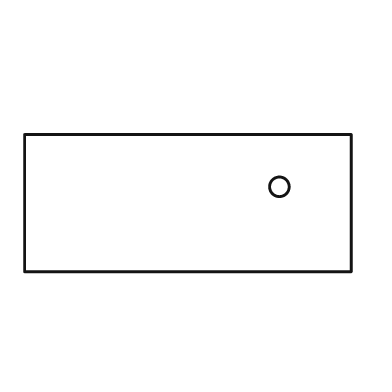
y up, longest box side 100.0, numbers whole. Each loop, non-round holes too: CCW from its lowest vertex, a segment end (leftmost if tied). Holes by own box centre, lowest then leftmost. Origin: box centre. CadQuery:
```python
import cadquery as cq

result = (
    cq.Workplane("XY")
    .moveTo(-50.0, -21.0)
    .lineTo(50.0, -21.0)
    .lineTo(50.0, 21.0)
    .lineTo(-50.0, 21.0)
    .close()
    .moveTo(28.0, 5.0)
    .circle(3.0)
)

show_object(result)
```